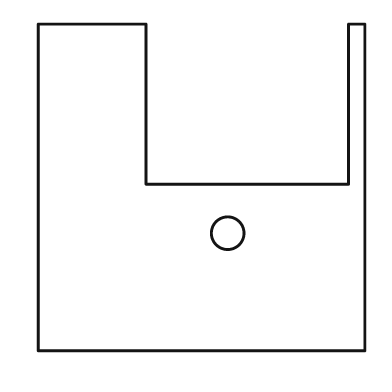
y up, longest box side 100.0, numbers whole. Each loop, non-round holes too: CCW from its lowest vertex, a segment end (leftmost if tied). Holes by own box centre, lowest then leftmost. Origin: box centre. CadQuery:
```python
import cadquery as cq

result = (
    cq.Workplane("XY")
    .moveTo(-50.0, -50.0)
    .lineTo(50.0, -50.0)
    .lineTo(50.0, 50.0)
    .lineTo(45.0, 50.0)
    .lineTo(45.0, 1.0)
    .lineTo(-17.0, 1.0)
    .lineTo(-17.0, 50.0)
    .lineTo(-50.0, 50.0)
    .close()
    .moveTo(8.0, -14.0)
    .circle(5.0)
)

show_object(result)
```